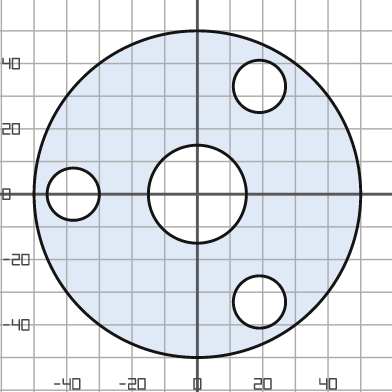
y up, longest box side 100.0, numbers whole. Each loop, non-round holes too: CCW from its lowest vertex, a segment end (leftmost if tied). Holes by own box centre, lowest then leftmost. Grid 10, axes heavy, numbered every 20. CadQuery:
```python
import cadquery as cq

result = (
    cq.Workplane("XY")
    .moveTo(0.0, 0.0)
    .circle(50.0)
    .moveTo(19.0, -33.0)
    .circle(8.0)
    .moveTo(-38.0, 0.0)
    .circle(8.0)
    .moveTo(0.0, 0.0)
    .circle(15.0)
    .moveTo(19.0, 33.0)
    .circle(8.0)
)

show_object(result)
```